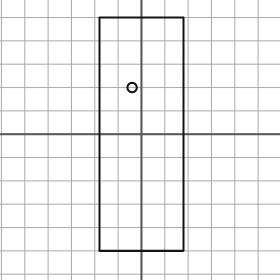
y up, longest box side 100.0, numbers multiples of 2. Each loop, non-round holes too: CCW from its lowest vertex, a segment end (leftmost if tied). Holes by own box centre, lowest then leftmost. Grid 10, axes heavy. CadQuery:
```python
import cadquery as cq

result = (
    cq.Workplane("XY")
    .moveTo(-18.0, -50.0)
    .lineTo(18.0, -50.0)
    .lineTo(18.0, 50.0)
    .lineTo(-18.0, 50.0)
    .close()
    .moveTo(-4.0, 20.0)
    .circle(2.0)
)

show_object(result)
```